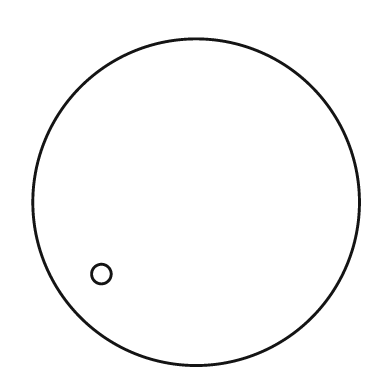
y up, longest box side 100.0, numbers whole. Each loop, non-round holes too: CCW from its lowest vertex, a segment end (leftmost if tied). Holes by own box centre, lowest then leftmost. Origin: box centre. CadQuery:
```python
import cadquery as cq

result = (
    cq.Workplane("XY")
    .moveTo(0.0, 0.0)
    .circle(50.0)
    .moveTo(-29.0, -22.0)
    .circle(3.0)
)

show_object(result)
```